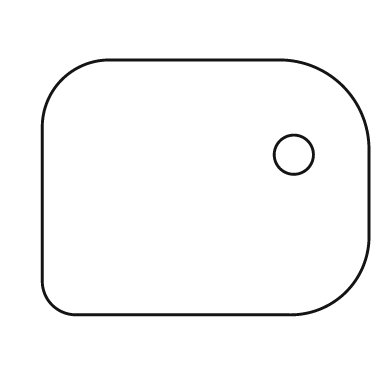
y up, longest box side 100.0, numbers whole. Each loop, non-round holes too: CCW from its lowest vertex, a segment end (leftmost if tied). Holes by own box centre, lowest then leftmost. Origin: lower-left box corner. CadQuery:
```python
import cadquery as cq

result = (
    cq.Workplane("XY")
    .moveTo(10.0, 0.0)
    .lineTo(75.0, 0.0)
    .threePointArc((93.0, 7.0), (100.0, 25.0))
    .lineTo(100.0, 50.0)
    .threePointArc((92.0, 70.0), (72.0, 78.0))
    .lineTo(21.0, 78.0)
    .threePointArc((6.0, 72.0), (0.0, 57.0))
    .lineTo(0.0, 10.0)
    .threePointArc((3.0, 3.0), (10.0, 0.0))
    .close()
    .moveTo(77.0, 49.0)
    .circle(6.0)
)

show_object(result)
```